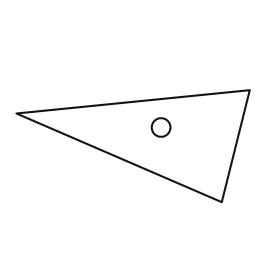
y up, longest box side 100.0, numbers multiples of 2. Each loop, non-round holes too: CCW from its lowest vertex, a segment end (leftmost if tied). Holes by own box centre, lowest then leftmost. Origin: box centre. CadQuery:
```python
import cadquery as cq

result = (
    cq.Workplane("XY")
    .moveTo(38.0, -24.0)
    .lineTo(50.0, 24.0)
    .lineTo(-50.0, 14.0)
    .close()
    .moveTo(12.0, 8.0)
    .circle(4.0)
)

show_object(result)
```